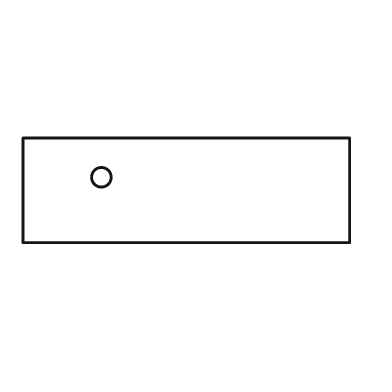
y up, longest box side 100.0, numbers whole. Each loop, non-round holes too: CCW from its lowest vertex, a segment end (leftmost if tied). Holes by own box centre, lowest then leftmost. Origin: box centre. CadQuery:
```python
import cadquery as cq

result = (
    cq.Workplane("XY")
    .moveTo(-50.0, -16.0)
    .lineTo(50.0, -16.0)
    .lineTo(50.0, 16.0)
    .lineTo(-50.0, 16.0)
    .close()
    .moveTo(-26.0, 4.0)
    .circle(3.0)
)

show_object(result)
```